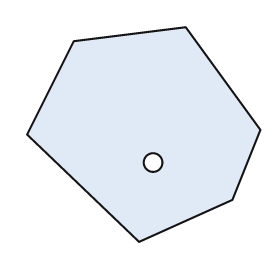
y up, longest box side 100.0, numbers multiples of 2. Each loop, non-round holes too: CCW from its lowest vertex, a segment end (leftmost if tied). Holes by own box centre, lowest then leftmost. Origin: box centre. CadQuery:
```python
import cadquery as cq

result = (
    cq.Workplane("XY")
    .moveTo(-2.0, -46.0)
    .lineTo(38.0, -28.0)
    .lineTo(50.0, 2.0)
    .lineTo(18.0, 46.0)
    .lineTo(-30.0, 40.0)
    .lineTo(-50.0, 0.0)
    .close()
    .moveTo(4.0, -12.0)
    .circle(4.0)
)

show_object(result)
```